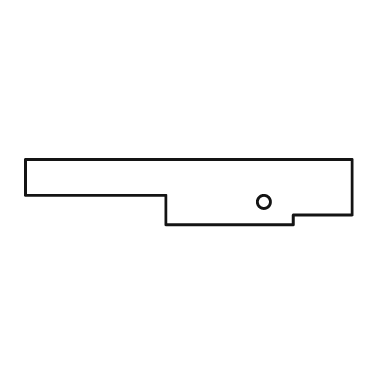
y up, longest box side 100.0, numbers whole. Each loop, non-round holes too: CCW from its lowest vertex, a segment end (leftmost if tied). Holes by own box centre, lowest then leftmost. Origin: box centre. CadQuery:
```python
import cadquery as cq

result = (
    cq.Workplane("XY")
    .moveTo(-7.0, -10.0)
    .lineTo(32.0, -10.0)
    .lineTo(32.0, -7.0)
    .lineTo(50.0, -7.0)
    .lineTo(50.0, 10.0)
    .lineTo(-50.0, 10.0)
    .lineTo(-50.0, -1.0)
    .lineTo(-7.0, -1.0)
    .close()
    .moveTo(23.0, -3.0)
    .circle(2.0)
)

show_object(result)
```